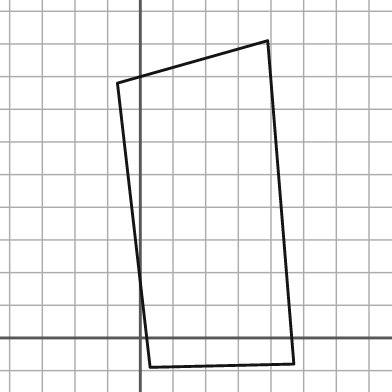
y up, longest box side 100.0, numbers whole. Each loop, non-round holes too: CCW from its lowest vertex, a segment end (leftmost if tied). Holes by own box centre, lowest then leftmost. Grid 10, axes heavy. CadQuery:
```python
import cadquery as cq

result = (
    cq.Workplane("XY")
    .moveTo(3.0, -9.0)
    .lineTo(47.0, -8.0)
    .lineTo(39.0, 91.0)
    .lineTo(-7.0, 78.0)
    .close()
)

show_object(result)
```